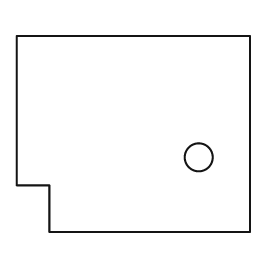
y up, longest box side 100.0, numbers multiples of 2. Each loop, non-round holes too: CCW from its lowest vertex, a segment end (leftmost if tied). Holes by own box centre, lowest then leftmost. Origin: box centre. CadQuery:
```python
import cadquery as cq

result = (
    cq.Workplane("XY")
    .moveTo(-36.0, -42.0)
    .lineTo(50.0, -42.0)
    .lineTo(50.0, 42.0)
    .lineTo(-50.0, 42.0)
    .lineTo(-50.0, -22.0)
    .lineTo(-36.0, -22.0)
    .close()
    .moveTo(28.0, -10.0)
    .circle(6.0)
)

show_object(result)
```